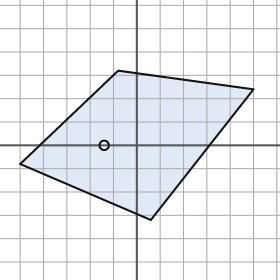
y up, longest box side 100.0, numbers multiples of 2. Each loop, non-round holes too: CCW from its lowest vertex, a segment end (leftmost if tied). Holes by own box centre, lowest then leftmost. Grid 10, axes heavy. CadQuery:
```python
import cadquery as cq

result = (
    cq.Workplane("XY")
    .moveTo(6.0, -32.0)
    .lineTo(50.0, 24.0)
    .lineTo(-8.0, 32.0)
    .lineTo(-50.0, -8.0)
    .close()
    .moveTo(-14.0, 0.0)
    .circle(2.0)
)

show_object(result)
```